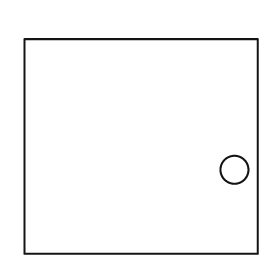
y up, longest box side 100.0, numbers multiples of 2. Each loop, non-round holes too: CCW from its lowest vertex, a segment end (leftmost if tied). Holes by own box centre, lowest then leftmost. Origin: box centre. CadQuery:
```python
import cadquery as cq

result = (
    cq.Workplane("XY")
    .moveTo(-50.0, -46.0)
    .lineTo(50.0, -46.0)
    .lineTo(50.0, 46.0)
    .lineTo(-50.0, 46.0)
    .close()
    .moveTo(40.0, -10.0)
    .circle(6.0)
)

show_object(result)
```